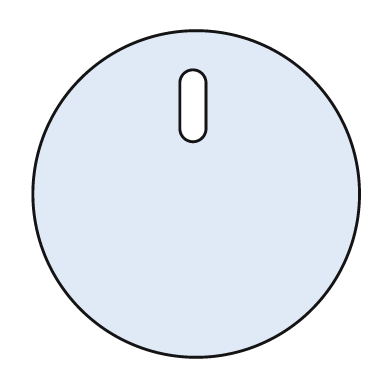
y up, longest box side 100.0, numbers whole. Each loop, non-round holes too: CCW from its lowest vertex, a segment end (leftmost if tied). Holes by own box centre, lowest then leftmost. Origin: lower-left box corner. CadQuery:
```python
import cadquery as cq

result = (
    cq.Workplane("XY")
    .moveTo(50.0, 50.0)
    .circle(50.0)
    .moveTo(45.0, 70.0)
    .threePointArc((49.0, 66.0), (53.0, 70.0))
    .lineTo(53.0, 84.0)
    .threePointArc((49.0, 88.0), (45.0, 84.0))
    .close()
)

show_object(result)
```